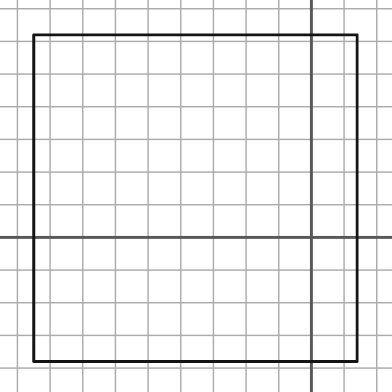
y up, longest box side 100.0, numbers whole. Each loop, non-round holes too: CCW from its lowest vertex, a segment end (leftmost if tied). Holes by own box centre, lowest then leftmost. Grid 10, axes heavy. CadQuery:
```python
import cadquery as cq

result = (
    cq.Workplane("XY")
    .moveTo(-85.0, -38.0)
    .lineTo(14.0, -38.0)
    .lineTo(14.0, 62.0)
    .lineTo(-85.0, 62.0)
    .close()
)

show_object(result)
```